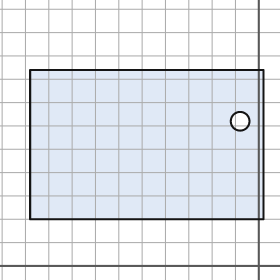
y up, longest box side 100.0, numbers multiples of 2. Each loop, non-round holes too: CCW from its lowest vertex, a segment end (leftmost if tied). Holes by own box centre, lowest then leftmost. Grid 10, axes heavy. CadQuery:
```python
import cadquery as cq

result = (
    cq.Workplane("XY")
    .moveTo(-98.0, 20.0)
    .lineTo(2.0, 20.0)
    .lineTo(2.0, 84.0)
    .lineTo(-98.0, 84.0)
    .close()
    .moveTo(-8.0, 62.0)
    .circle(4.0)
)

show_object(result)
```